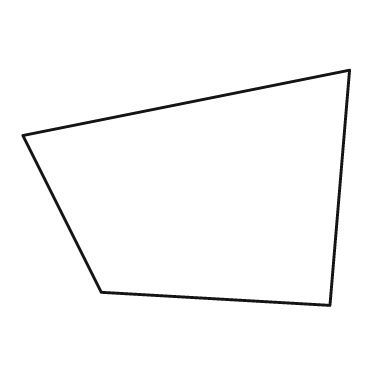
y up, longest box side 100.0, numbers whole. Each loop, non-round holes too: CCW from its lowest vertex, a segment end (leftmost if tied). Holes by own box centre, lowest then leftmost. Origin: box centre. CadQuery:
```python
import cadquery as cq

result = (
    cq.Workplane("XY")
    .moveTo(44.0, -36.0)
    .lineTo(50.0, 36.0)
    .lineTo(-50.0, 16.0)
    .lineTo(-26.0, -32.0)
    .close()
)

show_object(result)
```